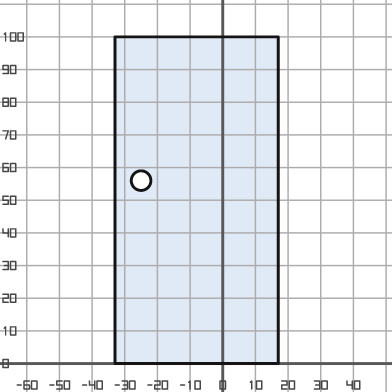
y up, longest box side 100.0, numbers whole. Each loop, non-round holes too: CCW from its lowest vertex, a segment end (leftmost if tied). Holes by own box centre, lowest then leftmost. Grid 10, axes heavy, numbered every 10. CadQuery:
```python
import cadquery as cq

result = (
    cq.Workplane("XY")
    .moveTo(-33.0, 0.0)
    .lineTo(17.0, 0.0)
    .lineTo(17.0, 100.0)
    .lineTo(-33.0, 100.0)
    .close()
    .moveTo(-25.0, 56.0)
    .circle(3.0)
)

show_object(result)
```